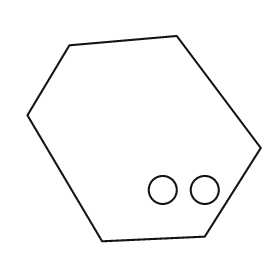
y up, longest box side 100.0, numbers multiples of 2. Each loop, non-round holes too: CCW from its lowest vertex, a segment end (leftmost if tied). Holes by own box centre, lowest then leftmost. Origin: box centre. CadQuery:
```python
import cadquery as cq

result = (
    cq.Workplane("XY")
    .moveTo(-18.0, -44.0)
    .lineTo(26.0, -42.0)
    .lineTo(50.0, -4.0)
    .lineTo(14.0, 44.0)
    .lineTo(-32.0, 40.0)
    .lineTo(-50.0, 10.0)
    .close()
    .moveTo(8.0, -22.0)
    .circle(6.0)
    .moveTo(26.0, -22.0)
    .circle(6.0)
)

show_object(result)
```